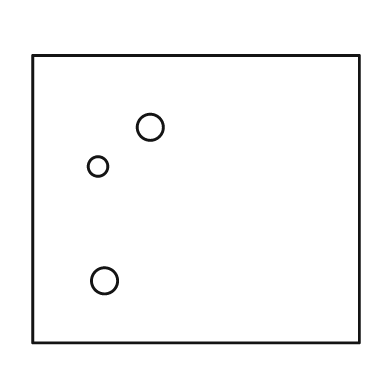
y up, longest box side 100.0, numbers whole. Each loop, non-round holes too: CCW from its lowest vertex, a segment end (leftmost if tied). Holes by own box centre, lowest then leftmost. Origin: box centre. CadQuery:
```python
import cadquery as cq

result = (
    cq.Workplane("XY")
    .moveTo(-50.0, -44.0)
    .lineTo(50.0, -44.0)
    .lineTo(50.0, 44.0)
    .lineTo(-50.0, 44.0)
    .close()
    .moveTo(-28.0, -25.0)
    .circle(4.0)
    .moveTo(-30.0, 10.0)
    .circle(3.0)
    .moveTo(-14.0, 22.0)
    .circle(4.0)
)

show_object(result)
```